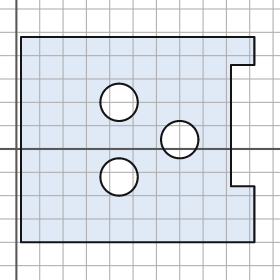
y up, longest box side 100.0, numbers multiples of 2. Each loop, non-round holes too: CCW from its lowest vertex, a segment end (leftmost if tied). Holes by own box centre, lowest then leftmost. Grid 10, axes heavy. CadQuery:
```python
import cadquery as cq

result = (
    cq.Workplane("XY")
    .moveTo(2.0, -40.0)
    .lineTo(102.0, -40.0)
    .lineTo(102.0, -16.0)
    .lineTo(92.0, -16.0)
    .lineTo(92.0, 36.0)
    .lineTo(102.0, 36.0)
    .lineTo(102.0, 48.0)
    .lineTo(2.0, 48.0)
    .close()
    .moveTo(44.0, -12.0)
    .circle(8.0)
    .moveTo(70.0, 4.0)
    .circle(8.0)
    .moveTo(44.0, 20.0)
    .circle(8.0)
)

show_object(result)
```